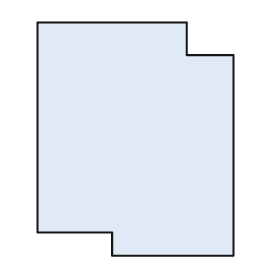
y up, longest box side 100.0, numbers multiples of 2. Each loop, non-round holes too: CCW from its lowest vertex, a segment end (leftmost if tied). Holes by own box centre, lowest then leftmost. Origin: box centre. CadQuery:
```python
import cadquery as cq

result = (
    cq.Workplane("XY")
    .moveTo(-10.0, -50.0)
    .lineTo(42.0, -50.0)
    .lineTo(42.0, 36.0)
    .lineTo(22.0, 36.0)
    .lineTo(22.0, 50.0)
    .lineTo(-42.0, 50.0)
    .lineTo(-42.0, -40.0)
    .lineTo(-10.0, -40.0)
    .close()
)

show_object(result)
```